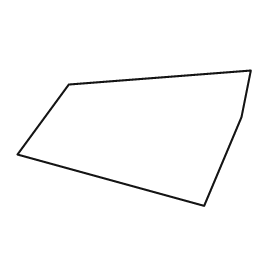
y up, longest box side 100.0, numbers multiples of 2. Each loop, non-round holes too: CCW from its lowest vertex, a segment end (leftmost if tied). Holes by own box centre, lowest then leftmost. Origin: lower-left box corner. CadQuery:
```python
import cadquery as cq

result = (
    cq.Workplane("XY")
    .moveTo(80.0, 0.0)
    .lineTo(96.0, 38.0)
    .lineTo(100.0, 58.0)
    .lineTo(22.0, 52.0)
    .lineTo(0.0, 22.0)
    .close()
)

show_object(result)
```